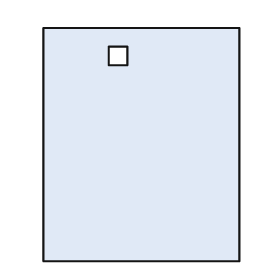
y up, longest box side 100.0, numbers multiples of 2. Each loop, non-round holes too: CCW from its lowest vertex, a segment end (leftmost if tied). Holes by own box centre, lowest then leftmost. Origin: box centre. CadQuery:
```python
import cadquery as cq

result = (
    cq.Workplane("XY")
    .moveTo(-42.0, -50.0)
    .lineTo(42.0, -50.0)
    .lineTo(42.0, 50.0)
    .lineTo(-42.0, 50.0)
    .close()
    .moveTo(-14.0, 34.0)
    .lineTo(-6.0, 34.0)
    .lineTo(-6.0, 42.0)
    .lineTo(-14.0, 42.0)
    .close()
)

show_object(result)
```